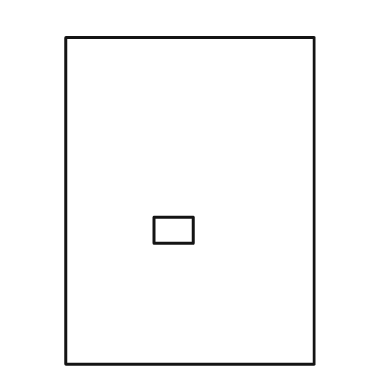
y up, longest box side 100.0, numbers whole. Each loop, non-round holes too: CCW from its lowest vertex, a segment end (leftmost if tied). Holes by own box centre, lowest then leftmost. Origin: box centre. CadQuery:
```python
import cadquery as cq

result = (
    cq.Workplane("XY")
    .moveTo(-38.0, -50.0)
    .lineTo(38.0, -50.0)
    .lineTo(38.0, 50.0)
    .lineTo(-38.0, 50.0)
    .close()
    .moveTo(-11.0, -13.0)
    .lineTo(1.0, -13.0)
    .lineTo(1.0, -5.0)
    .lineTo(-11.0, -5.0)
    .close()
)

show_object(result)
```